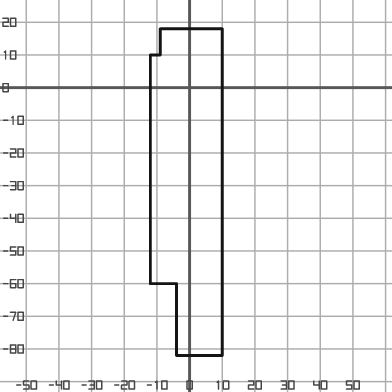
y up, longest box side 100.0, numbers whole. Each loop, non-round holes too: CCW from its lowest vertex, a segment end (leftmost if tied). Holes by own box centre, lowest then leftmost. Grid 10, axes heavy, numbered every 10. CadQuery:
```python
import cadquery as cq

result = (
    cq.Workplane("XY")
    .moveTo(-4.0, -82.0)
    .lineTo(10.0, -82.0)
    .lineTo(10.0, 18.0)
    .lineTo(-9.0, 18.0)
    .lineTo(-9.0, 10.0)
    .lineTo(-12.0, 10.0)
    .lineTo(-12.0, -60.0)
    .lineTo(-4.0, -60.0)
    .close()
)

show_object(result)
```